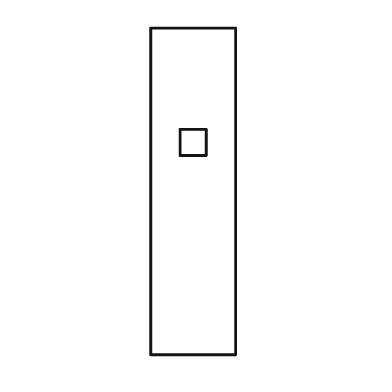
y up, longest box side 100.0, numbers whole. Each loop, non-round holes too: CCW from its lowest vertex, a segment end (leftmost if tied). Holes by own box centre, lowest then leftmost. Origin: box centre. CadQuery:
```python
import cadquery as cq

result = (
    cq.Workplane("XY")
    .moveTo(-13.0, -50.0)
    .lineTo(13.0, -50.0)
    .lineTo(13.0, 50.0)
    .lineTo(-13.0, 50.0)
    .close()
    .moveTo(-4.0, 11.0)
    .lineTo(4.0, 11.0)
    .lineTo(4.0, 19.0)
    .lineTo(-4.0, 19.0)
    .close()
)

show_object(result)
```